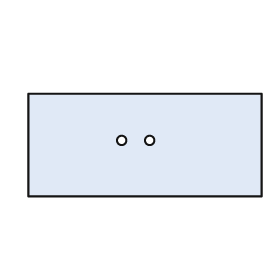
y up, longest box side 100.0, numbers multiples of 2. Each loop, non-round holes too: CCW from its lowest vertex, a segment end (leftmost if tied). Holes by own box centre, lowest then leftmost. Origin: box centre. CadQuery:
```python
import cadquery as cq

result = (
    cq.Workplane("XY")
    .moveTo(-50.0, -22.0)
    .lineTo(50.0, -22.0)
    .lineTo(50.0, 22.0)
    .lineTo(-50.0, 22.0)
    .close()
    .moveTo(-10.0, 2.0)
    .circle(2.0)
    .moveTo(2.0, 2.0)
    .circle(2.0)
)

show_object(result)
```